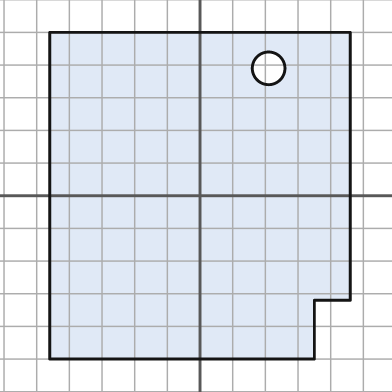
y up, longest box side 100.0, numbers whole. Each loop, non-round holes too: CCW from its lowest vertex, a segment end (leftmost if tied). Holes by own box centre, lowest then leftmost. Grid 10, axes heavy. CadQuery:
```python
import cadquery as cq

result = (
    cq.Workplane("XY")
    .moveTo(-46.0, -50.0)
    .lineTo(35.0, -50.0)
    .lineTo(35.0, -32.0)
    .lineTo(46.0, -32.0)
    .lineTo(46.0, 50.0)
    .lineTo(-46.0, 50.0)
    .close()
    .moveTo(21.0, 39.0)
    .circle(5.0)
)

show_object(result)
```